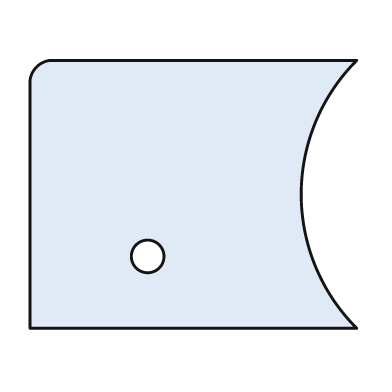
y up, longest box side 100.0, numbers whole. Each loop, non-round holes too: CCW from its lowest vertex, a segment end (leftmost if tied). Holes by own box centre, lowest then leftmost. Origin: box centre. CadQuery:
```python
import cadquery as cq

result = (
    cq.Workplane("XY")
    .moveTo(-50.0, -41.0)
    .lineTo(50.0, -41.0)
    .threePointArc((33.0, 0.0), (50.0, 41.0))
    .lineTo(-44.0, 41.0)
    .threePointArc((-48.0, 39.0), (-50.0, 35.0))
    .close()
    .moveTo(-14.0, -19.0)
    .circle(5.0)
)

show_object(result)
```